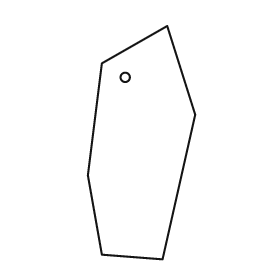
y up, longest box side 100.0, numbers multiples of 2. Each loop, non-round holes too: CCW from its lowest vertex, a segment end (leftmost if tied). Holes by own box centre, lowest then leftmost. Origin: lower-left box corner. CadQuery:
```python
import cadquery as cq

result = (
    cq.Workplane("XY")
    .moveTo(32.0, 0.0)
    .lineTo(46.0, 62.0)
    .lineTo(34.0, 100.0)
    .lineTo(6.0, 84.0)
    .lineTo(0.0, 36.0)
    .lineTo(6.0, 2.0)
    .close()
    .moveTo(16.0, 78.0)
    .circle(2.0)
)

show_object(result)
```